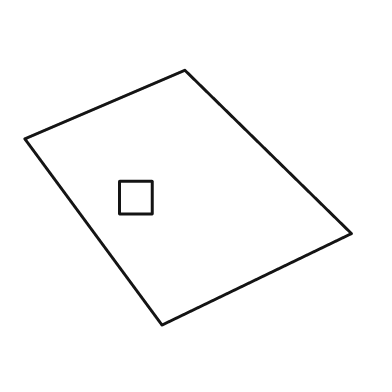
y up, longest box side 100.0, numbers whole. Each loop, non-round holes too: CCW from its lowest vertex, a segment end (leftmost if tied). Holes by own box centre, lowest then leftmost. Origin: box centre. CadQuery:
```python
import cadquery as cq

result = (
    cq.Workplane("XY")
    .moveTo(-8.0, -39.0)
    .lineTo(50.0, -11.0)
    .lineTo(-1.0, 39.0)
    .lineTo(-50.0, 18.0)
    .close()
    .moveTo(-21.0, -5.0)
    .lineTo(-11.0, -5.0)
    .lineTo(-11.0, 5.0)
    .lineTo(-21.0, 5.0)
    .close()
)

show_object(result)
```